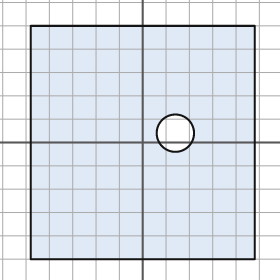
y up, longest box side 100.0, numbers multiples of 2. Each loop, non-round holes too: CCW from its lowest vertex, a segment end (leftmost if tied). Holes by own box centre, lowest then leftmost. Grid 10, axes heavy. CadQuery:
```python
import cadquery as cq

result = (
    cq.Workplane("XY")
    .moveTo(-48.0, -50.0)
    .lineTo(48.0, -50.0)
    .lineTo(48.0, 50.0)
    .lineTo(-48.0, 50.0)
    .close()
    .moveTo(14.0, 4.0)
    .circle(8.0)
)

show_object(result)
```